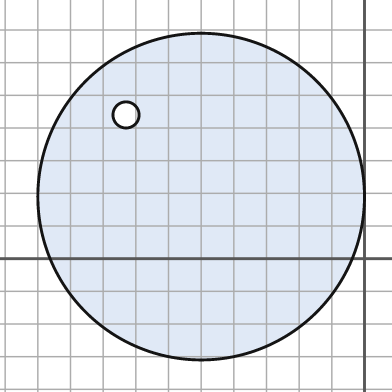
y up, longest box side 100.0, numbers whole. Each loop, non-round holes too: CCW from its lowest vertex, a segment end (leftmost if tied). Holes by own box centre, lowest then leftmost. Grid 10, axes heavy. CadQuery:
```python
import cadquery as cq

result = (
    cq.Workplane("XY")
    .moveTo(-50.0, 19.0)
    .circle(50.0)
    .moveTo(-73.0, 44.0)
    .circle(4.0)
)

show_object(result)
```